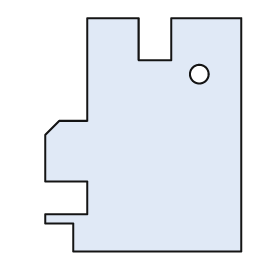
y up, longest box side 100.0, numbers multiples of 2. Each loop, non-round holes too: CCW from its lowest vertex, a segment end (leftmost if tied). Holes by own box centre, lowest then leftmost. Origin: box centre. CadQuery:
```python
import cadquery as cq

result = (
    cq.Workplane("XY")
    .moveTo(-30.0, -50.0)
    .lineTo(42.0, -50.0)
    .lineTo(42.0, 50.0)
    .lineTo(12.0, 50.0)
    .lineTo(12.0, 32.0)
    .lineTo(-2.0, 32.0)
    .lineTo(-2.0, 50.0)
    .lineTo(-24.0, 50.0)
    .lineTo(-24.0, 6.0)
    .lineTo(-36.0, 6.0)
    .lineTo(-42.0, 0.0)
    .lineTo(-42.0, -20.0)
    .lineTo(-24.0, -20.0)
    .lineTo(-24.0, -34.0)
    .lineTo(-42.0, -34.0)
    .lineTo(-42.0, -38.0)
    .lineTo(-30.0, -38.0)
    .close()
    .moveTo(24.0, 26.0)
    .circle(4.0)
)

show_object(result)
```